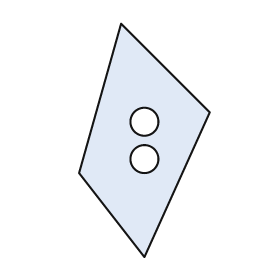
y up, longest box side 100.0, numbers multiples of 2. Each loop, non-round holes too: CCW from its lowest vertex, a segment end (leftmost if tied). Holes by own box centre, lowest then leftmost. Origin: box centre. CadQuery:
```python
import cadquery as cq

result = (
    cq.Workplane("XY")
    .moveTo(0.0, -50.0)
    .lineTo(28.0, 12.0)
    .lineTo(-10.0, 50.0)
    .lineTo(-28.0, -14.0)
    .close()
    .moveTo(0.0, -8.0)
    .circle(6.0)
    .moveTo(0.0, 8.0)
    .circle(6.0)
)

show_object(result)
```